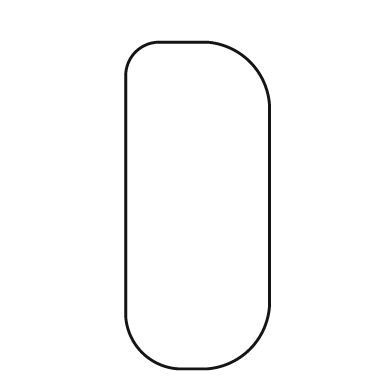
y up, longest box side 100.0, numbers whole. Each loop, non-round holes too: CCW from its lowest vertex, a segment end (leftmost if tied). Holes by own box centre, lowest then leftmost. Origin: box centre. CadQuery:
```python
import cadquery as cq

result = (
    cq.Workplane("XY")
    .moveTo(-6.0, -50.0)
    .lineTo(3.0, -50.0)
    .threePointArc((16.0, -44.0), (22.0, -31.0))
    .lineTo(22.0, 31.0)
    .threePointArc((16.0, 44.0), (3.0, 50.0))
    .lineTo(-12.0, 50.0)
    .threePointArc((-19.0, 47.0), (-22.0, 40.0))
    .lineTo(-22.0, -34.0)
    .threePointArc((-17.0, -45.0), (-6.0, -50.0))
    .close()
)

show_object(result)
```